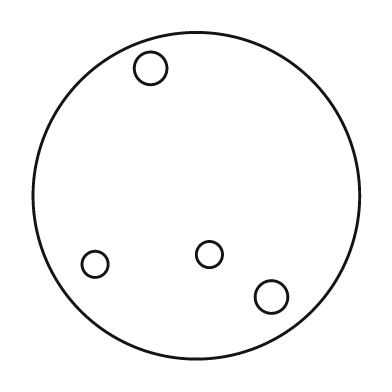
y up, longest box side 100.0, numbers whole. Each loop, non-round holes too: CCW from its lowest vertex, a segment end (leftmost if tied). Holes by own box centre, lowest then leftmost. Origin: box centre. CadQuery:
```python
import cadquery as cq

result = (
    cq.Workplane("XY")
    .moveTo(0.0, 0.0)
    .circle(50.0)
    .moveTo(23.0, -31.0)
    .circle(5.0)
    .moveTo(-31.0, -21.0)
    .circle(4.0)
    .moveTo(4.0, -18.0)
    .circle(4.0)
    .moveTo(-14.0, 39.0)
    .circle(5.0)
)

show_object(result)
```